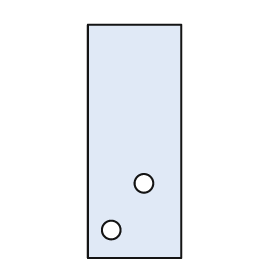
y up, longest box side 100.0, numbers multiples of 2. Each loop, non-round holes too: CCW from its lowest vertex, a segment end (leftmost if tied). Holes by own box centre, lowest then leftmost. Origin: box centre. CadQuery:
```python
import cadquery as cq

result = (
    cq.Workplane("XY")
    .moveTo(-20.0, -50.0)
    .lineTo(20.0, -50.0)
    .lineTo(20.0, 50.0)
    .lineTo(-20.0, 50.0)
    .close()
    .moveTo(-10.0, -38.0)
    .circle(4.0)
    .moveTo(4.0, -18.0)
    .circle(4.0)
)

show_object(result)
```